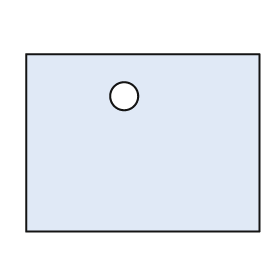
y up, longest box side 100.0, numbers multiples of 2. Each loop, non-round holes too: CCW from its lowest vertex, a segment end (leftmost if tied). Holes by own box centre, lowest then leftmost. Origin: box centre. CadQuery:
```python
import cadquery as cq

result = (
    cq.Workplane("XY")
    .moveTo(-50.0, -38.0)
    .lineTo(50.0, -38.0)
    .lineTo(50.0, 38.0)
    .lineTo(-50.0, 38.0)
    .close()
    .moveTo(-8.0, 20.0)
    .circle(6.0)
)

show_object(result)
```